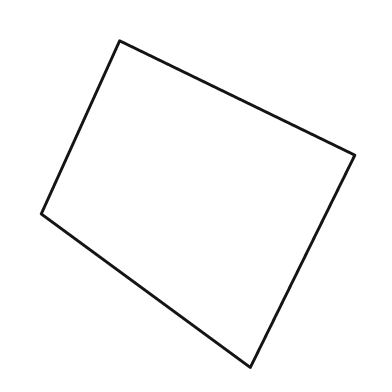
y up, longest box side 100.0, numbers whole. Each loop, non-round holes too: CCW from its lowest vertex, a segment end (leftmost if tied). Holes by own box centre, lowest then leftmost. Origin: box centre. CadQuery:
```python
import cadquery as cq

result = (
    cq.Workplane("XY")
    .moveTo(16.0, -50.0)
    .lineTo(48.0, 15.0)
    .lineTo(-24.0, 50.0)
    .lineTo(-48.0, -3.0)
    .close()
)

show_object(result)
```